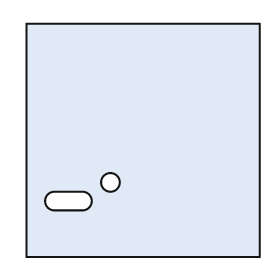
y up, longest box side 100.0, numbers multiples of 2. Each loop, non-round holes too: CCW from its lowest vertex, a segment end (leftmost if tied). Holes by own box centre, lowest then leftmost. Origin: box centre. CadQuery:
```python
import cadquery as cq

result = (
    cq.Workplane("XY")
    .moveTo(-50.0, -50.0)
    .lineTo(50.0, -50.0)
    .lineTo(50.0, 50.0)
    .lineTo(-50.0, 50.0)
    .close()
    .moveTo(-38.0, -30.0)
    .lineTo(-26.0, -30.0)
    .threePointArc((-22.0, -26.0), (-26.0, -22.0))
    .lineTo(-38.0, -22.0)
    .threePointArc((-42.0, -26.0), (-38.0, -30.0))
    .close()
    .moveTo(-14.0, -18.0)
    .circle(4.0)
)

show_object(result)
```